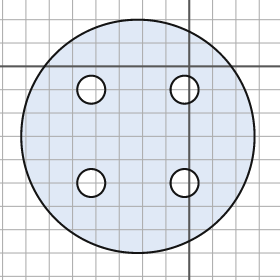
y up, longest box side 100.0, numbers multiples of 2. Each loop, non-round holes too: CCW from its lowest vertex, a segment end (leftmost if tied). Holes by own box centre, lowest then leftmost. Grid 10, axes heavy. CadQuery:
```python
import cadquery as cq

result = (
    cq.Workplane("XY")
    .moveTo(-22.0, -30.0)
    .circle(50.0)
    .moveTo(-42.0, -50.0)
    .circle(6.0)
    .moveTo(-2.0, -50.0)
    .circle(6.0)
    .moveTo(-42.0, -10.0)
    .circle(6.0)
    .moveTo(-2.0, -10.0)
    .circle(6.0)
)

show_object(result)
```